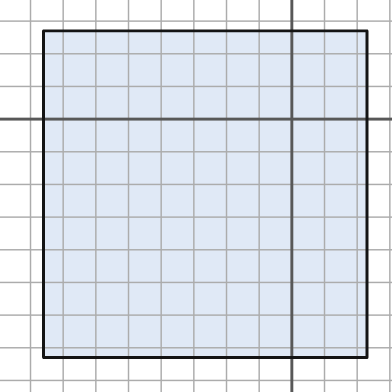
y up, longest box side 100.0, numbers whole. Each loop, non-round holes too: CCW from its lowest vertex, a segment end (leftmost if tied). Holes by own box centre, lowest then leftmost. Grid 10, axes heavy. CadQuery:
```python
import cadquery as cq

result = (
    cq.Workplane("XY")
    .moveTo(-76.0, -73.0)
    .lineTo(23.0, -73.0)
    .lineTo(23.0, 27.0)
    .lineTo(-76.0, 27.0)
    .close()
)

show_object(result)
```